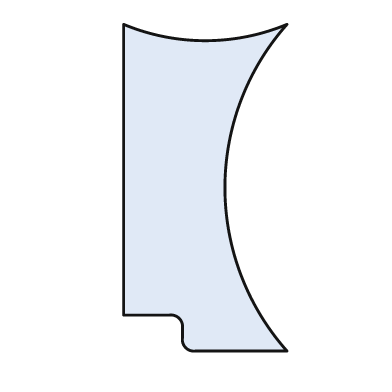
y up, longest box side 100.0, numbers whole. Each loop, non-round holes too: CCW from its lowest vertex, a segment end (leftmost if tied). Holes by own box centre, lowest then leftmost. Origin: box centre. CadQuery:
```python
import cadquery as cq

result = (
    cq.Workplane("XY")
    .moveTo(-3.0, -50.0)
    .lineTo(25.0, -50.0)
    .threePointArc((6.0, 0.0), (25.0, 50.0))
    .threePointArc((0.0, 45.0), (-25.0, 50.0))
    .lineTo(-25.0, -39.0)
    .lineTo(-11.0, -39.0)
    .threePointArc((-8.0, -40.0), (-7.0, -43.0))
    .lineTo(-7.0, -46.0)
    .threePointArc((-6.0, -49.0), (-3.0, -50.0))
    .close()
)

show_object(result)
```